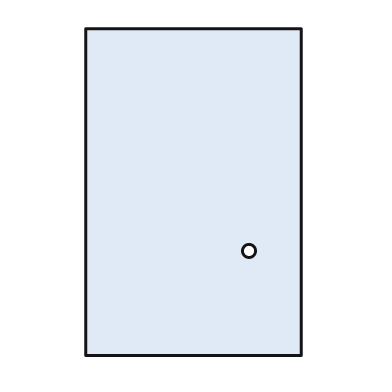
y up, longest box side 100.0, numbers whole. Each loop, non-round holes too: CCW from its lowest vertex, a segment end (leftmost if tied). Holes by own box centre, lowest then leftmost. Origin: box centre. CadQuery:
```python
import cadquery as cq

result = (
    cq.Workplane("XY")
    .moveTo(-33.0, -50.0)
    .lineTo(33.0, -50.0)
    .lineTo(33.0, 50.0)
    .lineTo(-33.0, 50.0)
    .close()
    .moveTo(17.0, -18.0)
    .circle(2.0)
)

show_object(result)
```